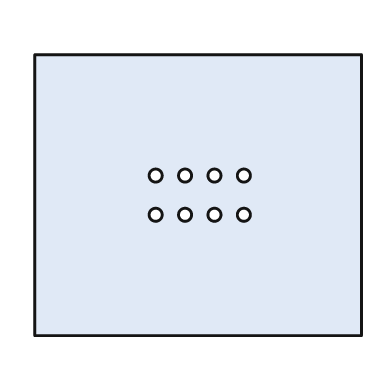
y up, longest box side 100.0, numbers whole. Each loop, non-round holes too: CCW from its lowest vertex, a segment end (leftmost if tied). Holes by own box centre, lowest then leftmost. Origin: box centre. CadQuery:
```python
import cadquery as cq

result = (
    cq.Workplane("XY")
    .moveTo(-50.0, -43.0)
    .lineTo(50.0, -43.0)
    .lineTo(50.0, 43.0)
    .lineTo(-50.0, 43.0)
    .close()
    .moveTo(-13.0, -6.0)
    .circle(2.0)
    .moveTo(-4.0, -6.0)
    .circle(2.0)
    .moveTo(5.0, -6.0)
    .circle(2.0)
    .moveTo(14.0, -6.0)
    .circle(2.0)
    .moveTo(-13.0, 6.0)
    .circle(2.0)
    .moveTo(-4.0, 6.0)
    .circle(2.0)
    .moveTo(5.0, 6.0)
    .circle(2.0)
    .moveTo(14.0, 6.0)
    .circle(2.0)
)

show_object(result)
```